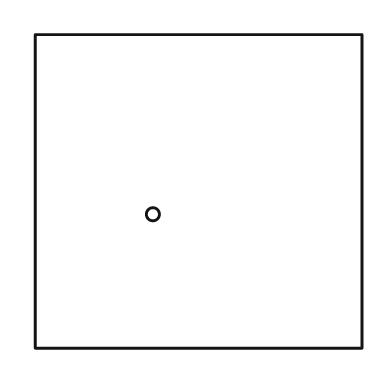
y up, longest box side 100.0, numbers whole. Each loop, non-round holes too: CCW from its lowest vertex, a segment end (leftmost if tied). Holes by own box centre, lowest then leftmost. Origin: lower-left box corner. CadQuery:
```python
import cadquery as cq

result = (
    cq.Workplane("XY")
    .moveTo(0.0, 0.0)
    .lineTo(100.0, 0.0)
    .lineTo(100.0, 96.0)
    .lineTo(0.0, 96.0)
    .close()
    .moveTo(36.0, 41.0)
    .circle(2.0)
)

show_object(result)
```